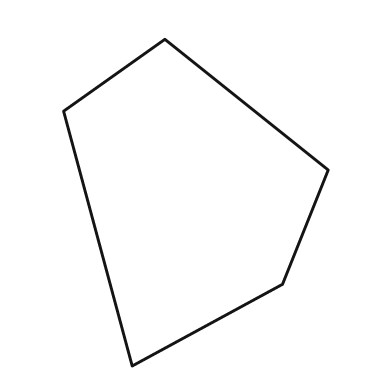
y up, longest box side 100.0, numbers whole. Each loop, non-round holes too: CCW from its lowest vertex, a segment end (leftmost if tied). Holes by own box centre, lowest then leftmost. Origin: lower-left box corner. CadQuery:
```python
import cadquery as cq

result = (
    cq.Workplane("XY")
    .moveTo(21.0, 0.0)
    .lineTo(67.0, 25.0)
    .lineTo(81.0, 60.0)
    .lineTo(31.0, 100.0)
    .lineTo(0.0, 78.0)
    .close()
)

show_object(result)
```